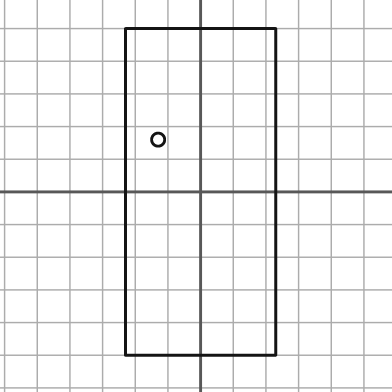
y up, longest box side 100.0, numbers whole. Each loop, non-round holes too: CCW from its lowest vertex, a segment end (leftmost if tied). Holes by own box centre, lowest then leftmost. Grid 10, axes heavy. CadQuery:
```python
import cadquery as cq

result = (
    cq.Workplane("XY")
    .moveTo(-23.0, -50.0)
    .lineTo(23.0, -50.0)
    .lineTo(23.0, 50.0)
    .lineTo(-23.0, 50.0)
    .close()
    .moveTo(-13.0, 16.0)
    .circle(2.0)
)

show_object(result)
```